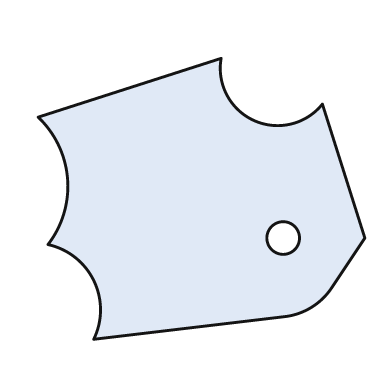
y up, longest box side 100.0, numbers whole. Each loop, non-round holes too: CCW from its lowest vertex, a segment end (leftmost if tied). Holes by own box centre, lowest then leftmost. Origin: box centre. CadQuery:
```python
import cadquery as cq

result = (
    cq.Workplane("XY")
    .moveTo(-33.0, -43.0)
    .lineTo(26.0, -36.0)
    .threePointArc((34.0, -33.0), (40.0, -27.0))
    .lineTo(50.0, -12.0)
    .lineTo(37.0, 29.0)
    .threePointArc((16.0, 24.0), (6.0, 43.0))
    .lineTo(-50.0, 25.0)
    .threePointArc((-41.0, 6.0), (-47.0, -14.0))
    .threePointArc((-33.0, -25.0), (-33.0, -43.0))
    .close()
    .moveTo(25.0, -12.0)
    .circle(5.0)
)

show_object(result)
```